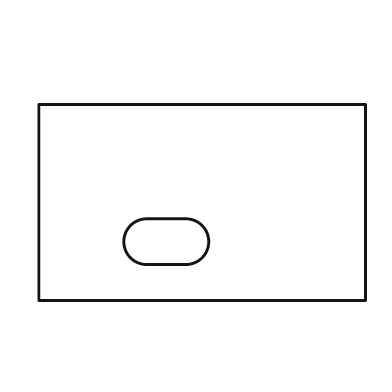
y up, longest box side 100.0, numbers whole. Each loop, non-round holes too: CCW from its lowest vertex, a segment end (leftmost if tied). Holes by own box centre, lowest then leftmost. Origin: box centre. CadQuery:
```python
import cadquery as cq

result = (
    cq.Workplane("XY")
    .moveTo(-50.0, -30.0)
    .lineTo(50.0, -30.0)
    .lineTo(50.0, 30.0)
    .lineTo(-50.0, 30.0)
    .close()
    .moveTo(-17.0, -19.0)
    .lineTo(-5.0, -19.0)
    .threePointArc((2.0, -12.0), (-5.0, -5.0))
    .lineTo(-17.0, -5.0)
    .threePointArc((-24.0, -12.0), (-17.0, -19.0))
    .close()
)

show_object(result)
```